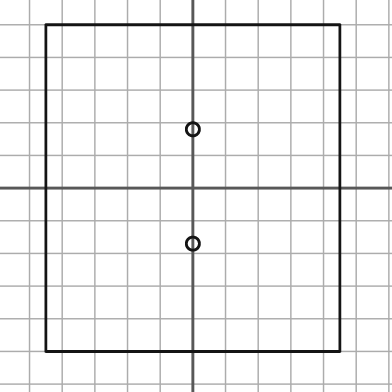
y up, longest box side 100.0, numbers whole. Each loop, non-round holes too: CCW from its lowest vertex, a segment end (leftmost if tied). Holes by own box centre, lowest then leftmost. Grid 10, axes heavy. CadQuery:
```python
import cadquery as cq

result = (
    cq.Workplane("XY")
    .moveTo(-45.0, -50.0)
    .lineTo(45.0, -50.0)
    .lineTo(45.0, 50.0)
    .lineTo(-45.0, 50.0)
    .close()
    .moveTo(0.0, -17.0)
    .circle(2.0)
    .moveTo(0.0, 18.0)
    .circle(2.0)
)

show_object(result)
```